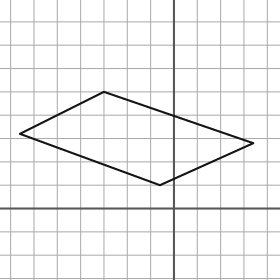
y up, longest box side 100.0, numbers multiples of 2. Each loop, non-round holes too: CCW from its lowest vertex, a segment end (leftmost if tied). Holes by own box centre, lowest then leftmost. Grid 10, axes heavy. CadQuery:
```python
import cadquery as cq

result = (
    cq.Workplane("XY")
    .moveTo(-6.0, 10.0)
    .lineTo(34.0, 28.0)
    .lineTo(-30.0, 50.0)
    .lineTo(-66.0, 32.0)
    .close()
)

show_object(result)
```